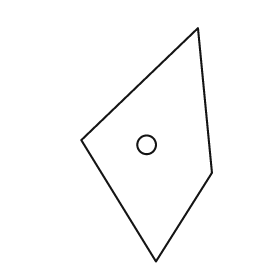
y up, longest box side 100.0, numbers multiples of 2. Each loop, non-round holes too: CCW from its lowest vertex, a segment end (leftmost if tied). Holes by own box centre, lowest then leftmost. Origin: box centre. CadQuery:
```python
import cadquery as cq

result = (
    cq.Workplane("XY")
    .moveTo(4.0, -50.0)
    .lineTo(28.0, -12.0)
    .lineTo(22.0, 50.0)
    .lineTo(-28.0, 2.0)
    .close()
    .moveTo(0.0, 0.0)
    .circle(4.0)
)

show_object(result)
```